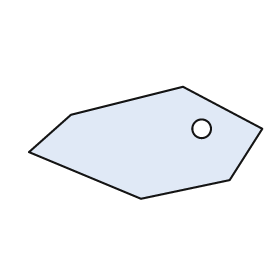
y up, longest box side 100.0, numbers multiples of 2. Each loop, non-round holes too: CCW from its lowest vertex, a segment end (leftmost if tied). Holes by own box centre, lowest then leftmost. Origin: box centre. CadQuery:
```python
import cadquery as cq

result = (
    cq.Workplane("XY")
    .moveTo(-2.0, -24.0)
    .lineTo(36.0, -16.0)
    .lineTo(50.0, 6.0)
    .lineTo(16.0, 24.0)
    .lineTo(-32.0, 12.0)
    .lineTo(-50.0, -4.0)
    .close()
    .moveTo(24.0, 6.0)
    .circle(4.0)
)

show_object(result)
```